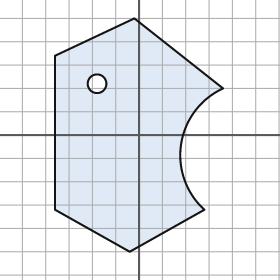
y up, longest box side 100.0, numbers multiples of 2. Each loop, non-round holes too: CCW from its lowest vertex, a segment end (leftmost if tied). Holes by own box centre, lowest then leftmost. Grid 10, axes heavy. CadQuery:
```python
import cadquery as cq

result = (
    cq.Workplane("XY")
    .moveTo(-4.0, -50.0)
    .lineTo(28.0, -32.0)
    .threePointArc((18.0, -4.0), (36.0, 20.0))
    .lineTo(-2.0, 50.0)
    .lineTo(-36.0, 34.0)
    .lineTo(-36.0, -32.0)
    .close()
    .moveTo(-18.0, 22.0)
    .circle(4.0)
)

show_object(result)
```